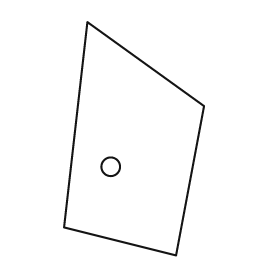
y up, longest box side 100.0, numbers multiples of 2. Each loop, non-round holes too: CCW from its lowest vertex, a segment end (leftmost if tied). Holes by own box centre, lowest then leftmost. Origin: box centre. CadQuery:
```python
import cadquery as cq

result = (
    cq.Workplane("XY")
    .moveTo(18.0, -50.0)
    .lineTo(30.0, 14.0)
    .lineTo(-20.0, 50.0)
    .lineTo(-30.0, -38.0)
    .close()
    .moveTo(-10.0, -12.0)
    .circle(4.0)
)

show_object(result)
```